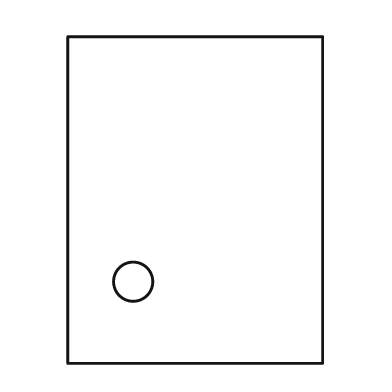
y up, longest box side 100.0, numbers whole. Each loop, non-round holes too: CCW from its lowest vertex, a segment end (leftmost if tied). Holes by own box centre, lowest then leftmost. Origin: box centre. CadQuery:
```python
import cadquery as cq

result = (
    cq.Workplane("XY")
    .moveTo(-39.0, -50.0)
    .lineTo(39.0, -50.0)
    .lineTo(39.0, 50.0)
    .lineTo(-39.0, 50.0)
    .close()
    .moveTo(-19.0, -25.0)
    .circle(6.0)
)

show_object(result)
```